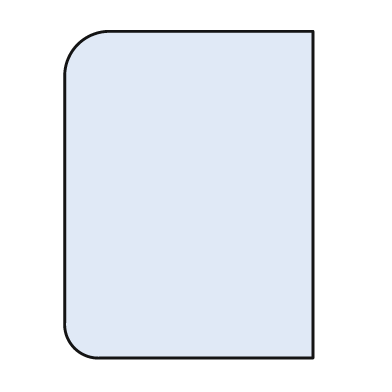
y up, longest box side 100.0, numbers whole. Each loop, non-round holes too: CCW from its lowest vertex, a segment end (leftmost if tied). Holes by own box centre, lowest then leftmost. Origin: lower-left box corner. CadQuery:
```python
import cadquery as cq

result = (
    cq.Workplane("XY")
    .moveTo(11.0, 0.0)
    .lineTo(76.0, 0.0)
    .lineTo(76.0, 100.0)
    .lineTo(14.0, 100.0)
    .threePointArc((4.0, 96.0), (0.0, 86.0))
    .lineTo(0.0, 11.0)
    .threePointArc((3.0, 3.0), (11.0, 0.0))
    .close()
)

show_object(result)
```